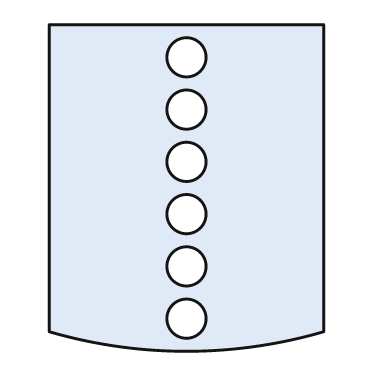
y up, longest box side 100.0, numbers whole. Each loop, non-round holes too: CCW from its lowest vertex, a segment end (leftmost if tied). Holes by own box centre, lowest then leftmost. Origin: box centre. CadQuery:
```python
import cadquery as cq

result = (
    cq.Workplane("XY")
    .moveTo(-42.0, -44.0)
    .threePointArc((0.0, -50.0), (42.0, -44.0))
    .lineTo(42.0, 50.0)
    .lineTo(-42.0, 50.0)
    .close()
    .moveTo(0.0, -40.0)
    .circle(6.0)
    .moveTo(0.0, -24.0)
    .circle(6.0)
    .moveTo(0.0, -8.0)
    .circle(6.0)
    .moveTo(0.0, 8.0)
    .circle(6.0)
    .moveTo(0.0, 24.0)
    .circle(6.0)
    .moveTo(0.0, 40.0)
    .circle(6.0)
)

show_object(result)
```